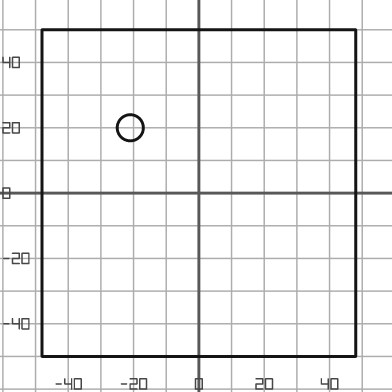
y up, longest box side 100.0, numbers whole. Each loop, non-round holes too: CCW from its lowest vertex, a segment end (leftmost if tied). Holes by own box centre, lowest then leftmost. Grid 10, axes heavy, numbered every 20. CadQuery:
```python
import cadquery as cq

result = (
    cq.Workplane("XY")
    .moveTo(-48.0, -50.0)
    .lineTo(48.0, -50.0)
    .lineTo(48.0, 50.0)
    .lineTo(-48.0, 50.0)
    .close()
    .moveTo(-21.0, 20.0)
    .circle(4.0)
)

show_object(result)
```